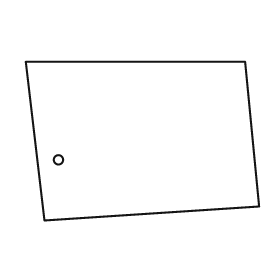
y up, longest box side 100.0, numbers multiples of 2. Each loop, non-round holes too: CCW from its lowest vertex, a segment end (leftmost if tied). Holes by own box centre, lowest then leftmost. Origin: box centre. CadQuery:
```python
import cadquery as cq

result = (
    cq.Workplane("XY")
    .moveTo(-42.0, -34.0)
    .lineTo(50.0, -28.0)
    .lineTo(44.0, 34.0)
    .lineTo(-50.0, 34.0)
    .close()
    .moveTo(-36.0, -8.0)
    .circle(2.0)
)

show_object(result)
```